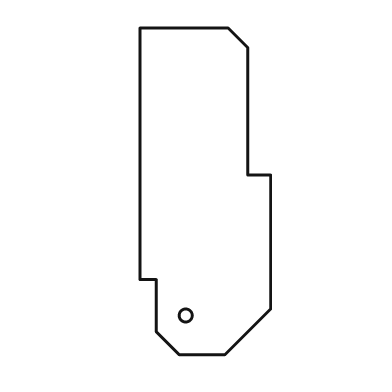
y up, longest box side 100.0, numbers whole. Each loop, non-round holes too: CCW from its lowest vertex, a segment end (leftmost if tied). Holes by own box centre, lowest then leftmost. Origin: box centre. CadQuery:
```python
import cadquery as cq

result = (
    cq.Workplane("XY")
    .moveTo(-8.0, -50.0)
    .lineTo(6.0, -50.0)
    .lineTo(20.0, -36.0)
    .lineTo(20.0, 5.0)
    .lineTo(13.0, 5.0)
    .lineTo(13.0, 44.0)
    .lineTo(7.0, 50.0)
    .lineTo(-20.0, 50.0)
    .lineTo(-20.0, -27.0)
    .lineTo(-15.0, -27.0)
    .lineTo(-15.0, -43.0)
    .close()
    .moveTo(-6.0, -38.0)
    .circle(2.0)
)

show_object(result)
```